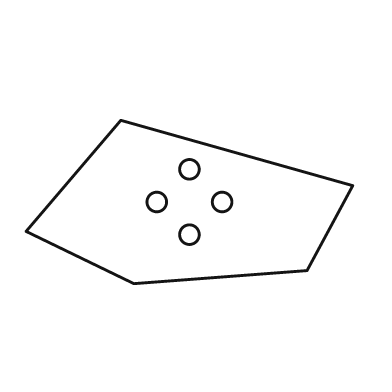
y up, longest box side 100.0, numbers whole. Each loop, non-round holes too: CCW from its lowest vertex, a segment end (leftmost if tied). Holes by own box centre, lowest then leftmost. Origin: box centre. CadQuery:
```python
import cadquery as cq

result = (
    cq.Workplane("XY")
    .moveTo(-17.0, -25.0)
    .lineTo(36.0, -21.0)
    .lineTo(50.0, 5.0)
    .lineTo(-21.0, 25.0)
    .lineTo(-50.0, -9.0)
    .close()
    .moveTo(0.0, -10.0)
    .circle(3.0)
    .moveTo(-10.0, 0.0)
    .circle(3.0)
    .moveTo(10.0, 0.0)
    .circle(3.0)
    .moveTo(0.0, 10.0)
    .circle(3.0)
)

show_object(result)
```